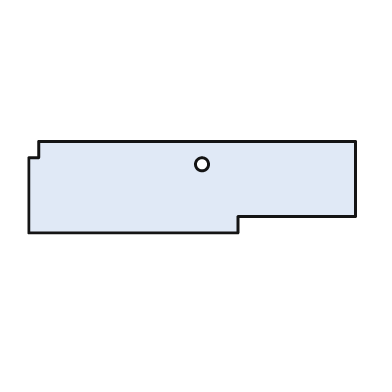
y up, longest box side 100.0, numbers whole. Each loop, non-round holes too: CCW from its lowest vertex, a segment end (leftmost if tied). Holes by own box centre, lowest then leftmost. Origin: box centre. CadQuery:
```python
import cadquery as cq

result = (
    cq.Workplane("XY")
    .moveTo(-50.0, -14.0)
    .lineTo(14.0, -14.0)
    .lineTo(14.0, -9.0)
    .lineTo(50.0, -9.0)
    .lineTo(50.0, 14.0)
    .lineTo(-47.0, 14.0)
    .lineTo(-47.0, 9.0)
    .lineTo(-50.0, 9.0)
    .close()
    .moveTo(3.0, 7.0)
    .circle(2.0)
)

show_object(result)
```